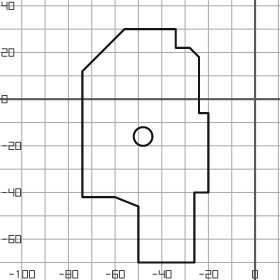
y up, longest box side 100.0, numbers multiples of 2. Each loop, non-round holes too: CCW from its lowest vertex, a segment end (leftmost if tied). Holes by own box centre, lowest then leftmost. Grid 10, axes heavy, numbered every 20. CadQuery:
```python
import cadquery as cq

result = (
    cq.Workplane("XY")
    .moveTo(-50.0, -70.0)
    .lineTo(-26.0, -70.0)
    .lineTo(-26.0, -40.0)
    .lineTo(-20.0, -40.0)
    .lineTo(-20.0, -6.0)
    .lineTo(-24.0, -6.0)
    .lineTo(-24.0, 18.0)
    .lineTo(-28.0, 22.0)
    .lineTo(-34.0, 22.0)
    .lineTo(-34.0, 30.0)
    .lineTo(-56.0, 30.0)
    .lineTo(-74.0, 12.0)
    .lineTo(-74.0, -42.0)
    .lineTo(-60.0, -42.0)
    .lineTo(-50.0, -46.0)
    .close()
    .moveTo(-48.0, -16.0)
    .circle(4.0)
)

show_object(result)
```